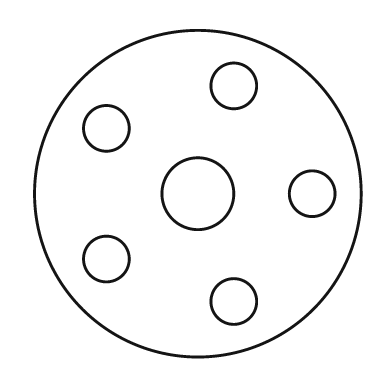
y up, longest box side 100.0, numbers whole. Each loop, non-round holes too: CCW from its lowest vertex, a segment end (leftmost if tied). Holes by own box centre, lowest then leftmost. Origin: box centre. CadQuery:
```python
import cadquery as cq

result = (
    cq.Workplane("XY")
    .moveTo(0.0, 0.0)
    .circle(50.0)
    .moveTo(11.0, -33.0)
    .circle(7.0)
    .moveTo(-28.0, -20.0)
    .circle(7.0)
    .moveTo(0.0, 0.0)
    .circle(11.0)
    .moveTo(35.0, 0.0)
    .circle(7.0)
    .moveTo(-28.0, 20.0)
    .circle(7.0)
    .moveTo(11.0, 33.0)
    .circle(7.0)
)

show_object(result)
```